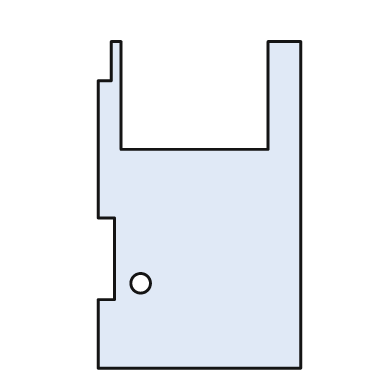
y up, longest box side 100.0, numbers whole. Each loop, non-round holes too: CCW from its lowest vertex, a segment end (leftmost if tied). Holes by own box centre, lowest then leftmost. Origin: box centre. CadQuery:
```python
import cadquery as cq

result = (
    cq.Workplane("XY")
    .moveTo(-31.0, -50.0)
    .lineTo(31.0, -50.0)
    .lineTo(31.0, 50.0)
    .lineTo(21.0, 50.0)
    .lineTo(21.0, 17.0)
    .lineTo(-24.0, 17.0)
    .lineTo(-24.0, 50.0)
    .lineTo(-27.0, 50.0)
    .lineTo(-27.0, 38.0)
    .lineTo(-31.0, 38.0)
    .lineTo(-31.0, -4.0)
    .lineTo(-26.0, -4.0)
    .lineTo(-26.0, -29.0)
    .lineTo(-31.0, -29.0)
    .close()
    .moveTo(-18.0, -24.0)
    .circle(3.0)
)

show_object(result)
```